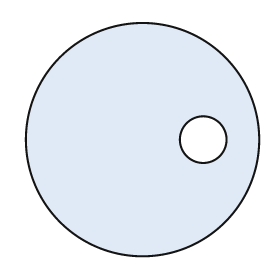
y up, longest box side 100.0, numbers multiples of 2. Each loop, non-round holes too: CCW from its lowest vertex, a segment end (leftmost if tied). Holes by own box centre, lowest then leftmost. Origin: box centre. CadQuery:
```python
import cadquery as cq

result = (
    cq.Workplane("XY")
    .moveTo(0.0, 0.0)
    .circle(50.0)
    .moveTo(26.0, 0.0)
    .circle(10.0)
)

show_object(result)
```